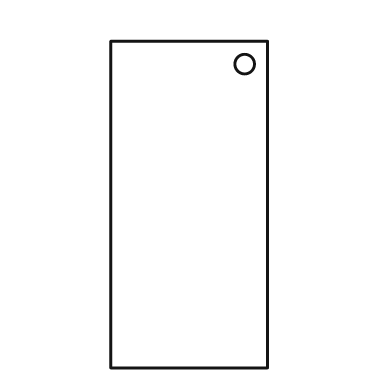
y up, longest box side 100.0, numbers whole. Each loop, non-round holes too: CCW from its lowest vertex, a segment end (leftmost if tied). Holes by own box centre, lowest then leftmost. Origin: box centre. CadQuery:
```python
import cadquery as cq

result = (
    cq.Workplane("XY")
    .moveTo(-24.0, -50.0)
    .lineTo(24.0, -50.0)
    .lineTo(24.0, 50.0)
    .lineTo(-24.0, 50.0)
    .close()
    .moveTo(17.0, 43.0)
    .circle(3.0)
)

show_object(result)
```